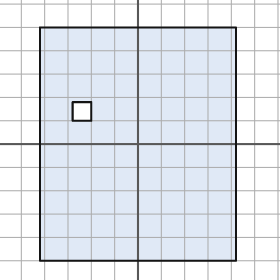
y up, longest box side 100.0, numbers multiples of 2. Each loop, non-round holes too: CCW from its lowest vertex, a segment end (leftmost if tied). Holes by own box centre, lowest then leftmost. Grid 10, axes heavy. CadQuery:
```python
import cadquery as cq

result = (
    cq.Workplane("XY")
    .moveTo(-42.0, -50.0)
    .lineTo(42.0, -50.0)
    .lineTo(42.0, 50.0)
    .lineTo(-42.0, 50.0)
    .close()
    .moveTo(-28.0, 10.0)
    .lineTo(-20.0, 10.0)
    .lineTo(-20.0, 18.0)
    .lineTo(-28.0, 18.0)
    .close()
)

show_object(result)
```